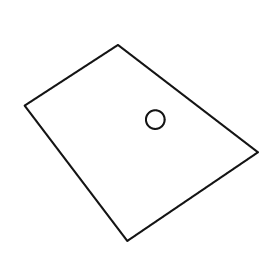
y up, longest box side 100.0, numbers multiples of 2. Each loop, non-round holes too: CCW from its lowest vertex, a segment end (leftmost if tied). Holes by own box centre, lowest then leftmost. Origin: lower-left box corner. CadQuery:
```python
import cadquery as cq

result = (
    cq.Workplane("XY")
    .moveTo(44.0, 0.0)
    .lineTo(100.0, 38.0)
    .lineTo(40.0, 84.0)
    .lineTo(0.0, 58.0)
    .close()
    .moveTo(56.0, 52.0)
    .circle(4.0)
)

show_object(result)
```